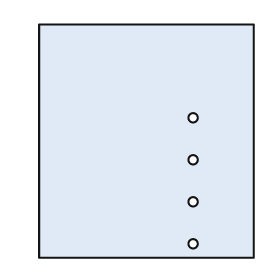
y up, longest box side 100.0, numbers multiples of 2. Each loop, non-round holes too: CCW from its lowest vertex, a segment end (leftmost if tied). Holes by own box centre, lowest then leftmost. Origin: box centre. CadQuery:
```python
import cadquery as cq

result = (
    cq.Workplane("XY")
    .moveTo(-46.0, -50.0)
    .lineTo(46.0, -50.0)
    .lineTo(46.0, 50.0)
    .lineTo(-46.0, 50.0)
    .close()
    .moveTo(20.0, -44.0)
    .circle(2.0)
    .moveTo(20.0, -26.0)
    .circle(2.0)
    .moveTo(20.0, -8.0)
    .circle(2.0)
    .moveTo(20.0, 10.0)
    .circle(2.0)
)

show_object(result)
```